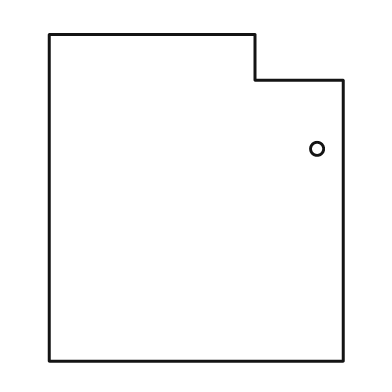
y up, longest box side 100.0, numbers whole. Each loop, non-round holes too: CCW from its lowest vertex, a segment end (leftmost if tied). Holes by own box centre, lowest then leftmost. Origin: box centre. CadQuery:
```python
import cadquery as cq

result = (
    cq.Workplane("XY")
    .moveTo(-45.0, -50.0)
    .lineTo(45.0, -50.0)
    .lineTo(45.0, 36.0)
    .lineTo(18.0, 36.0)
    .lineTo(18.0, 50.0)
    .lineTo(-45.0, 50.0)
    .close()
    .moveTo(37.0, 15.0)
    .circle(2.0)
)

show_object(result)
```